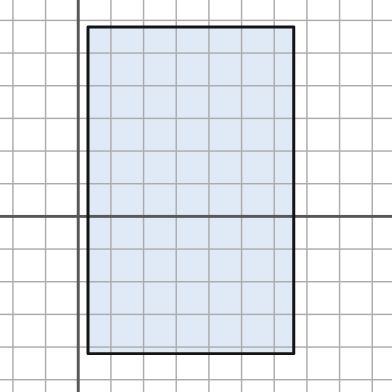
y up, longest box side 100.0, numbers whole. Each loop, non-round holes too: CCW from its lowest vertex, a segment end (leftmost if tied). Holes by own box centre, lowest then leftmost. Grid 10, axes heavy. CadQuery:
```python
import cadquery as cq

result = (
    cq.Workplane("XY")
    .moveTo(3.0, -42.0)
    .lineTo(66.0, -42.0)
    .lineTo(66.0, 58.0)
    .lineTo(3.0, 58.0)
    .close()
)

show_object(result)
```